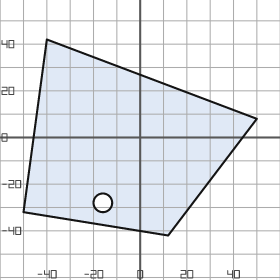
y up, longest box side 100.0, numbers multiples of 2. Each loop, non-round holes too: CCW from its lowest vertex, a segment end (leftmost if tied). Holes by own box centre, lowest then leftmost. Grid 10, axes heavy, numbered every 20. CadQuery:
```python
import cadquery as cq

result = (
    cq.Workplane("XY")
    .moveTo(12.0, -42.0)
    .lineTo(50.0, 8.0)
    .lineTo(-40.0, 42.0)
    .lineTo(-50.0, -32.0)
    .close()
    .moveTo(-16.0, -28.0)
    .circle(4.0)
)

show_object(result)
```